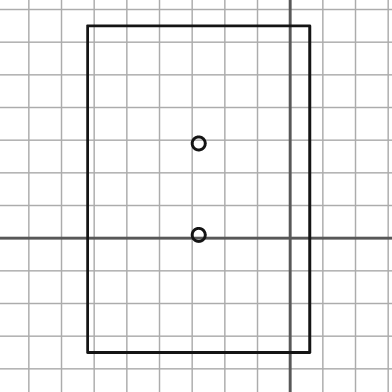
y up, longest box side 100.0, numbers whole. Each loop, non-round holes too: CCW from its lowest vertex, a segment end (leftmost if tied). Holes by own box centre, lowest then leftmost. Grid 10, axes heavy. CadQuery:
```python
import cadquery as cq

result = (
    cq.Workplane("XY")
    .moveTo(-62.0, -35.0)
    .lineTo(6.0, -35.0)
    .lineTo(6.0, 65.0)
    .lineTo(-62.0, 65.0)
    .close()
    .moveTo(-28.0, 1.0)
    .circle(2.0)
    .moveTo(-28.0, 29.0)
    .circle(2.0)
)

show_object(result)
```